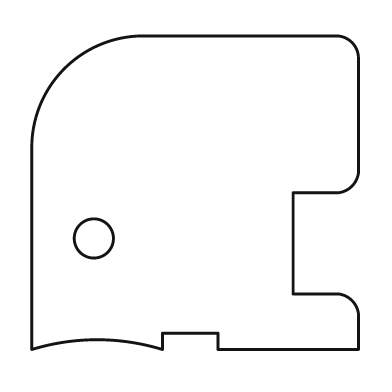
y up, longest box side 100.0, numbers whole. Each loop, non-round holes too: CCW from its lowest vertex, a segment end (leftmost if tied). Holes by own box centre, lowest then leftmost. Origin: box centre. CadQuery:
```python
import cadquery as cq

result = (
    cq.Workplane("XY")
    .moveTo(-50.0, -48.0)
    .threePointArc((-30.0, -45.0), (-10.0, -48.0))
    .lineTo(-10.0, -43.0)
    .lineTo(7.0, -43.0)
    .lineTo(7.0, -48.0)
    .lineTo(50.0, -48.0)
    .lineTo(50.0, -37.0)
    .threePointArc((48.0, -33.0), (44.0, -31.0))
    .lineTo(30.0, -31.0)
    .lineTo(30.0, 0.0)
    .lineTo(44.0, 0.0)
    .threePointArc((48.0, 2.0), (50.0, 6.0))
    .lineTo(50.0, 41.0)
    .threePointArc((48.0, 46.0), (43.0, 48.0))
    .lineTo(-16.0, 48.0)
    .threePointArc((-40.0, 38.0), (-50.0, 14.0))
    .close()
    .moveTo(-31.0, -14.0)
    .circle(6.0)
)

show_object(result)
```